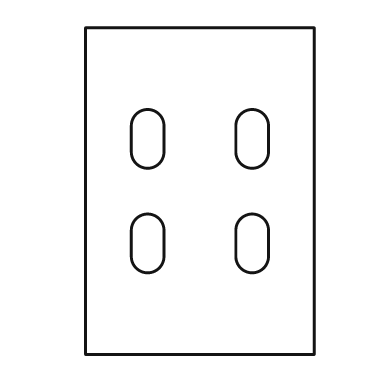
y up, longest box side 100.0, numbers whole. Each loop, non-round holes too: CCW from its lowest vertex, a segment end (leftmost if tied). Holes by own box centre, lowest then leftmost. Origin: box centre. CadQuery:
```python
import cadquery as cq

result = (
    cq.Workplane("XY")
    .moveTo(-35.0, -50.0)
    .lineTo(35.0, -50.0)
    .lineTo(35.0, 50.0)
    .lineTo(-35.0, 50.0)
    .close()
    .moveTo(-21.0, -20.0)
    .threePointArc((-16.0, -25.0), (-11.0, -20.0))
    .lineTo(-11.0, -12.0)
    .threePointArc((-16.0, -7.0), (-21.0, -12.0))
    .close()
    .moveTo(11.0, -20.0)
    .threePointArc((16.0, -25.0), (21.0, -20.0))
    .lineTo(21.0, -12.0)
    .threePointArc((16.0, -7.0), (11.0, -12.0))
    .close()
    .moveTo(-21.0, 12.0)
    .threePointArc((-16.0, 7.0), (-11.0, 12.0))
    .lineTo(-11.0, 20.0)
    .threePointArc((-16.0, 25.0), (-21.0, 20.0))
    .close()
    .moveTo(11.0, 12.0)
    .threePointArc((16.0, 7.0), (21.0, 12.0))
    .lineTo(21.0, 20.0)
    .threePointArc((16.0, 25.0), (11.0, 20.0))
    .close()
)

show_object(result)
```